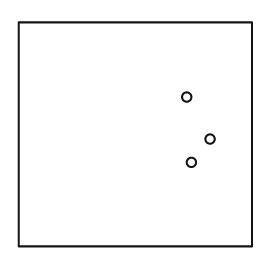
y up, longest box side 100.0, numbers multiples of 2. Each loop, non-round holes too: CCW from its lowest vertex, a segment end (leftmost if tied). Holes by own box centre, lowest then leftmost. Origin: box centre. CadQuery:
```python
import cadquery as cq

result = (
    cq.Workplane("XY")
    .moveTo(-50.0, -48.0)
    .lineTo(50.0, -48.0)
    .lineTo(50.0, 48.0)
    .lineTo(-50.0, 48.0)
    .close()
    .moveTo(24.0, -12.0)
    .circle(2.0)
    .moveTo(32.0, -2.0)
    .circle(2.0)
    .moveTo(22.0, 16.0)
    .circle(2.0)
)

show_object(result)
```